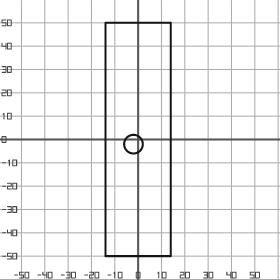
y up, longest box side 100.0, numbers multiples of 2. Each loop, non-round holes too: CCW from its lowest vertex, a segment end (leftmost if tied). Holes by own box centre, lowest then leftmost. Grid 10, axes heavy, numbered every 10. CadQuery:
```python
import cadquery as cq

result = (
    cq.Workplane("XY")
    .moveTo(-14.0, -50.0)
    .lineTo(14.0, -50.0)
    .lineTo(14.0, 50.0)
    .lineTo(-14.0, 50.0)
    .close()
    .moveTo(-2.0, -2.0)
    .circle(4.0)
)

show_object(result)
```